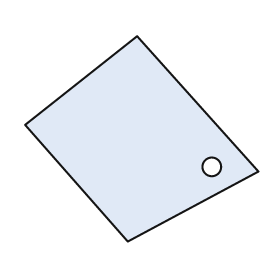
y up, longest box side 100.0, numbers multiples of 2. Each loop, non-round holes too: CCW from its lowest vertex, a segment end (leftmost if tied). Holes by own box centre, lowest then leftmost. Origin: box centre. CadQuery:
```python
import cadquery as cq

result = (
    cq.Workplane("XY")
    .moveTo(-6.0, -44.0)
    .lineTo(50.0, -14.0)
    .lineTo(-2.0, 44.0)
    .lineTo(-50.0, 6.0)
    .close()
    .moveTo(30.0, -12.0)
    .circle(4.0)
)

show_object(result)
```